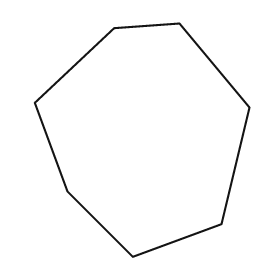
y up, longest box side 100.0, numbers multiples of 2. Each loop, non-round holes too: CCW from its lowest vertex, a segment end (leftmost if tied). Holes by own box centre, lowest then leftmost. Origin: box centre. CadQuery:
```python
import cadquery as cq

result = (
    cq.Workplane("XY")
    .moveTo(-4.0, -50.0)
    .lineTo(34.0, -36.0)
    .lineTo(46.0, 14.0)
    .lineTo(16.0, 50.0)
    .lineTo(-12.0, 48.0)
    .lineTo(-46.0, 16.0)
    .lineTo(-32.0, -22.0)
    .close()
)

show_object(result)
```